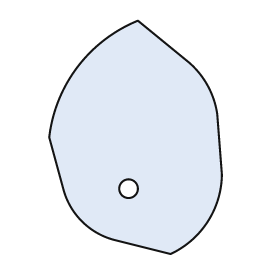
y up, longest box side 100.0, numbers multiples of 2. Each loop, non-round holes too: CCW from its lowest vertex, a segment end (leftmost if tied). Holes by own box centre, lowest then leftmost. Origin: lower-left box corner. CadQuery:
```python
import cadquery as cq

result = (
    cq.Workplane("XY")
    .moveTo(52.0, 0.0)
    .threePointArc((68.0, 14.0), (74.0, 34.0))
    .lineTo(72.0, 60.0)
    .threePointArc((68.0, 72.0), (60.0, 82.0))
    .lineTo(38.0, 100.0)
    .threePointArc((12.0, 80.0), (0.0, 50.0))
    .lineTo(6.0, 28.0)
    .threePointArc((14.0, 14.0), (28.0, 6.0))
    .close()
    .moveTo(34.0, 28.0)
    .circle(4.0)
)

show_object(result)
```